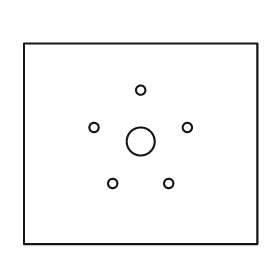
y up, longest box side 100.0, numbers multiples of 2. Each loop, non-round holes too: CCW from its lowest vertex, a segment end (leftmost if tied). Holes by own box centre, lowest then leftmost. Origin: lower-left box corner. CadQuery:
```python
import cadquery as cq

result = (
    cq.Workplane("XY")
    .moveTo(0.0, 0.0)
    .lineTo(100.0, 0.0)
    .lineTo(100.0, 86.0)
    .lineTo(0.0, 86.0)
    .close()
    .moveTo(38.0, 26.0)
    .circle(2.0)
    .moveTo(62.0, 26.0)
    .circle(2.0)
    .moveTo(50.0, 44.0)
    .circle(6.0)
    .moveTo(30.0, 50.0)
    .circle(2.0)
    .moveTo(70.0, 50.0)
    .circle(2.0)
    .moveTo(50.0, 66.0)
    .circle(2.0)
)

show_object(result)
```